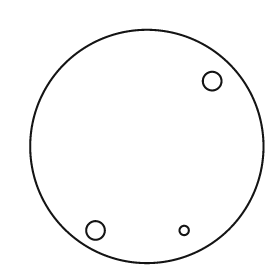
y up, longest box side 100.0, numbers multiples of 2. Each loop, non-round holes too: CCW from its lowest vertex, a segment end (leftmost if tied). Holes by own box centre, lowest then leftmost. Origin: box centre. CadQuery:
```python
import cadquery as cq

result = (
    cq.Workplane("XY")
    .moveTo(0.0, 0.0)
    .circle(50.0)
    .moveTo(-22.0, -36.0)
    .circle(4.0)
    .moveTo(16.0, -36.0)
    .circle(2.0)
    .moveTo(28.0, 28.0)
    .circle(4.0)
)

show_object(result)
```